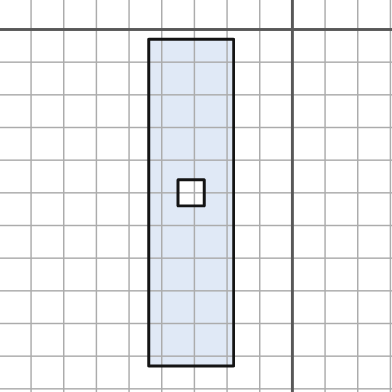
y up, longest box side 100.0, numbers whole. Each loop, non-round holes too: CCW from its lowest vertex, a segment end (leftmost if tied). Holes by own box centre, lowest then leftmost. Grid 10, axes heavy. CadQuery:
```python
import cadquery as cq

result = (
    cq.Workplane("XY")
    .moveTo(-44.0, -103.0)
    .lineTo(-18.0, -103.0)
    .lineTo(-18.0, -3.0)
    .lineTo(-44.0, -3.0)
    .close()
    .moveTo(-35.0, -54.0)
    .lineTo(-27.0, -54.0)
    .lineTo(-27.0, -46.0)
    .lineTo(-35.0, -46.0)
    .close()
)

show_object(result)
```